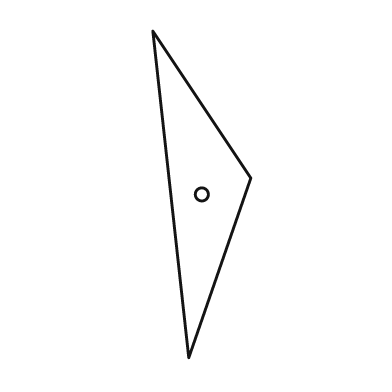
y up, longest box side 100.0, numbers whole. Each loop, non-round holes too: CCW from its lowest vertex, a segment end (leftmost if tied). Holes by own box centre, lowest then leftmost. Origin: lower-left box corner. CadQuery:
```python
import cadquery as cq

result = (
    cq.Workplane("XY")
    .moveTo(11.0, 0.0)
    .lineTo(30.0, 55.0)
    .lineTo(0.0, 100.0)
    .close()
    .moveTo(15.0, 50.0)
    .circle(2.0)
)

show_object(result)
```